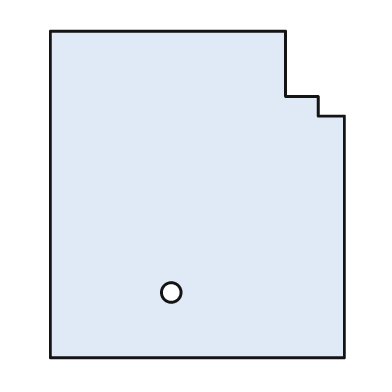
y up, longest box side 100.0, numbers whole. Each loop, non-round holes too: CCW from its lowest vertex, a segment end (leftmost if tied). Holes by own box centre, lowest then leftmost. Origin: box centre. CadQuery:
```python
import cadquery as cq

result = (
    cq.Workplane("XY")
    .moveTo(-45.0, -50.0)
    .lineTo(45.0, -50.0)
    .lineTo(45.0, 24.0)
    .lineTo(37.0, 24.0)
    .lineTo(37.0, 30.0)
    .lineTo(27.0, 30.0)
    .lineTo(27.0, 50.0)
    .lineTo(-45.0, 50.0)
    .close()
    .moveTo(-8.0, -30.0)
    .circle(3.0)
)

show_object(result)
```